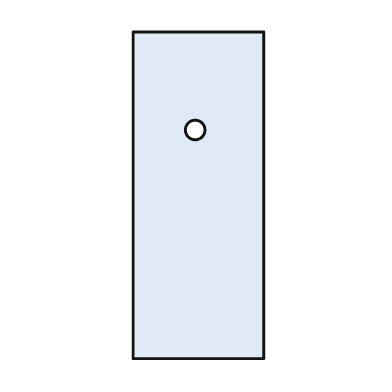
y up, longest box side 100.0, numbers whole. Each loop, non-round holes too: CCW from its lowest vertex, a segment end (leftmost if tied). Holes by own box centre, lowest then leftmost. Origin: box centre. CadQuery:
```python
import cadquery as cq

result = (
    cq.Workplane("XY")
    .moveTo(-20.0, -50.0)
    .lineTo(20.0, -50.0)
    .lineTo(20.0, 50.0)
    .lineTo(-20.0, 50.0)
    .close()
    .moveTo(-1.0, 20.0)
    .circle(3.0)
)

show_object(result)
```